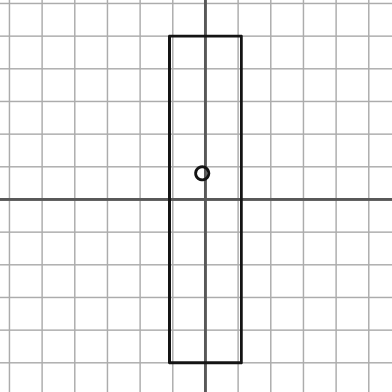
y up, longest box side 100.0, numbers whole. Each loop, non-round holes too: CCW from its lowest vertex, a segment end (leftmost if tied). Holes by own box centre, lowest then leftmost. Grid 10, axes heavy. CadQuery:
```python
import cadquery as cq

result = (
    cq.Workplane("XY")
    .moveTo(-11.0, -50.0)
    .lineTo(11.0, -50.0)
    .lineTo(11.0, 50.0)
    .lineTo(-11.0, 50.0)
    .close()
    .moveTo(-1.0, 8.0)
    .circle(2.0)
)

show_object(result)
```